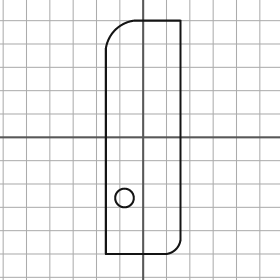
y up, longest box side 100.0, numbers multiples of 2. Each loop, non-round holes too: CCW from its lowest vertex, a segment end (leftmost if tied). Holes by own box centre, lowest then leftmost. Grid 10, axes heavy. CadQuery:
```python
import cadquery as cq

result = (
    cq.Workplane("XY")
    .moveTo(-16.0, -50.0)
    .lineTo(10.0, -50.0)
    .threePointArc((14.0, -48.0), (16.0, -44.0))
    .lineTo(16.0, 50.0)
    .lineTo(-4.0, 50.0)
    .threePointArc((-12.0, 46.0), (-16.0, 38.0))
    .close()
    .moveTo(-8.0, -26.0)
    .circle(4.0)
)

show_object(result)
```